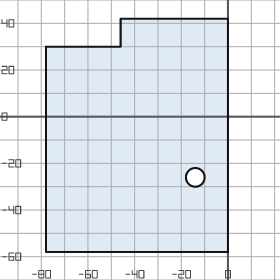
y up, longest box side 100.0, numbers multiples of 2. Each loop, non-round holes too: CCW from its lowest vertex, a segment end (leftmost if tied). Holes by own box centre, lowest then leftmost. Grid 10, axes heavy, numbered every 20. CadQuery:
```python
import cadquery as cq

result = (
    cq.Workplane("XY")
    .moveTo(-78.0, -58.0)
    .lineTo(0.0, -58.0)
    .lineTo(0.0, 42.0)
    .lineTo(-46.0, 42.0)
    .lineTo(-46.0, 30.0)
    .lineTo(-78.0, 30.0)
    .close()
    .moveTo(-14.0, -26.0)
    .circle(4.0)
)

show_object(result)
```